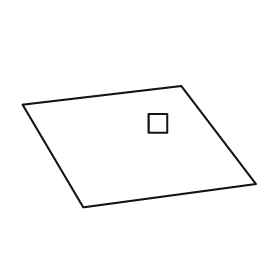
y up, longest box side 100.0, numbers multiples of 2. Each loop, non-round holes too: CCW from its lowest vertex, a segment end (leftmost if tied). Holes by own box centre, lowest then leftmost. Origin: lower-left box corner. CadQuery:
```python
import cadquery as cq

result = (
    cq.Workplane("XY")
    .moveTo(26.0, 0.0)
    .lineTo(100.0, 10.0)
    .lineTo(68.0, 52.0)
    .lineTo(0.0, 44.0)
    .close()
    .moveTo(54.0, 32.0)
    .lineTo(62.0, 32.0)
    .lineTo(62.0, 40.0)
    .lineTo(54.0, 40.0)
    .close()
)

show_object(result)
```